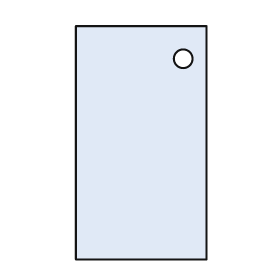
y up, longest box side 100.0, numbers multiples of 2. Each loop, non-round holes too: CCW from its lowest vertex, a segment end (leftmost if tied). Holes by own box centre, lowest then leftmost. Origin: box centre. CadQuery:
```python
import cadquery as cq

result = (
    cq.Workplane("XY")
    .moveTo(-28.0, -50.0)
    .lineTo(28.0, -50.0)
    .lineTo(28.0, 50.0)
    .lineTo(-28.0, 50.0)
    .close()
    .moveTo(18.0, 36.0)
    .circle(4.0)
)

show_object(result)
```